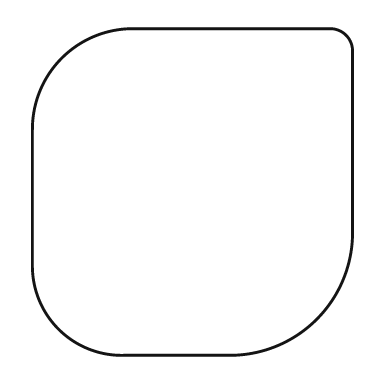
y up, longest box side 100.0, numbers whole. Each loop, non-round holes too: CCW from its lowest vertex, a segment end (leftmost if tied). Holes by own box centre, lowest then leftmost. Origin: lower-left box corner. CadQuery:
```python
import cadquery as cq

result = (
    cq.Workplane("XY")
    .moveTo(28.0, 0.0)
    .lineTo(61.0, 0.0)
    .threePointArc((87.0, 11.0), (98.0, 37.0))
    .lineTo(98.0, 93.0)
    .threePointArc((96.0, 98.0), (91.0, 100.0))
    .lineTo(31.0, 100.0)
    .threePointArc((9.0, 91.0), (0.0, 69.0))
    .lineTo(0.0, 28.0)
    .threePointArc((8.0, 8.0), (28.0, 0.0))
    .close()
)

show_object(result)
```